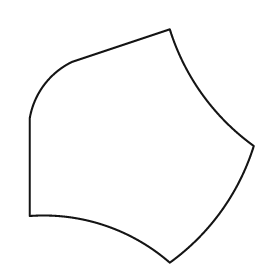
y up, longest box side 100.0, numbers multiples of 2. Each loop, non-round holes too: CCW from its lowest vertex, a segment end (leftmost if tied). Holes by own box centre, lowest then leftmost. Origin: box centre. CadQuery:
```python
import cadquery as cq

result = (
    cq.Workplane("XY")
    .moveTo(12.0, -50.0)
    .threePointArc((34.0, -28.0), (48.0, 0.0))
    .threePointArc((26.0, 22.0), (12.0, 50.0))
    .lineTo(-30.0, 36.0)
    .threePointArc((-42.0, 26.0), (-48.0, 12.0))
    .lineTo(-48.0, -30.0)
    .threePointArc((-16.0, -34.0), (12.0, -50.0))
    .close()
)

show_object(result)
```